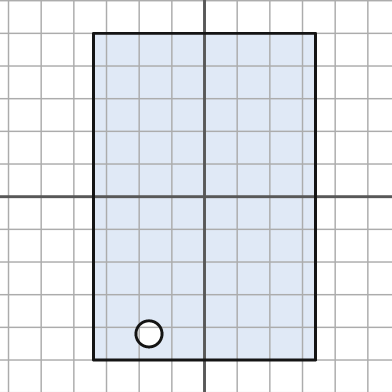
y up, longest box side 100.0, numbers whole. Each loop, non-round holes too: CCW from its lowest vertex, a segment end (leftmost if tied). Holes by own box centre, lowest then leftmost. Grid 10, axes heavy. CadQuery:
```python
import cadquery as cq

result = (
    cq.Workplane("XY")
    .moveTo(-34.0, -50.0)
    .lineTo(34.0, -50.0)
    .lineTo(34.0, 50.0)
    .lineTo(-34.0, 50.0)
    .close()
    .moveTo(-17.0, -42.0)
    .circle(4.0)
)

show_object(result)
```